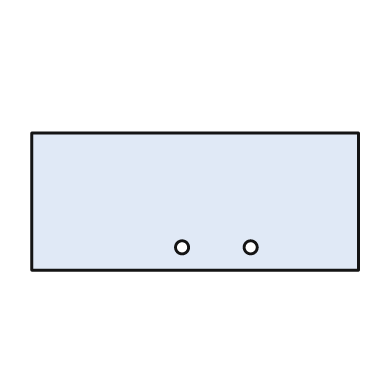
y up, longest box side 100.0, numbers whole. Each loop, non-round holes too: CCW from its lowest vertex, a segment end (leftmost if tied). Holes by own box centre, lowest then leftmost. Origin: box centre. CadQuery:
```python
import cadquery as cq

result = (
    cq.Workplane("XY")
    .moveTo(-50.0, -21.0)
    .lineTo(50.0, -21.0)
    .lineTo(50.0, 21.0)
    .lineTo(-50.0, 21.0)
    .close()
    .moveTo(-4.0, -14.0)
    .circle(2.0)
    .moveTo(17.0, -14.0)
    .circle(2.0)
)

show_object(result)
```